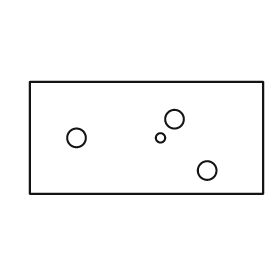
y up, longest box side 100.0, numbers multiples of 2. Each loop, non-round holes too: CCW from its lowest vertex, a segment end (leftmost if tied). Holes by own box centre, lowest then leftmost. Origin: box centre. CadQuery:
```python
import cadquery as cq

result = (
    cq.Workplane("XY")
    .moveTo(-50.0, -24.0)
    .lineTo(50.0, -24.0)
    .lineTo(50.0, 24.0)
    .lineTo(-50.0, 24.0)
    .close()
    .moveTo(26.0, -14.0)
    .circle(4.0)
    .moveTo(-30.0, 0.0)
    .circle(4.0)
    .moveTo(6.0, 0.0)
    .circle(2.0)
    .moveTo(12.0, 8.0)
    .circle(4.0)
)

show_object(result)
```